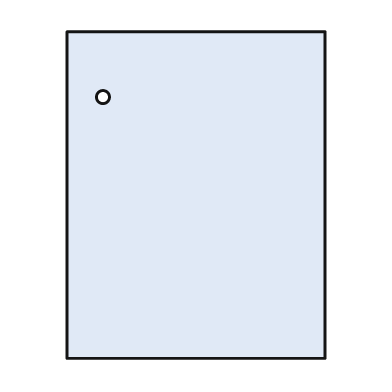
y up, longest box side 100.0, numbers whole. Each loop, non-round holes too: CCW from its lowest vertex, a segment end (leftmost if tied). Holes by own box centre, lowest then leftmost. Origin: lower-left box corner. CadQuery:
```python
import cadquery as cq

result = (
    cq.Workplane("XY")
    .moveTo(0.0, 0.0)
    .lineTo(79.0, 0.0)
    .lineTo(79.0, 100.0)
    .lineTo(0.0, 100.0)
    .close()
    .moveTo(11.0, 80.0)
    .circle(2.0)
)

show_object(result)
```